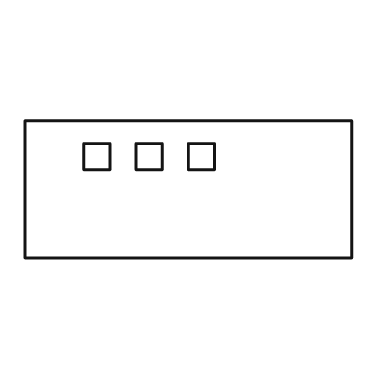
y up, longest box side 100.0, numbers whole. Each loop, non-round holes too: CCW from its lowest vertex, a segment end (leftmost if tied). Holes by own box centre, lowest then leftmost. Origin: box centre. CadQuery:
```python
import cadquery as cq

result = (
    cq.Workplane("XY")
    .moveTo(-50.0, -21.0)
    .lineTo(50.0, -21.0)
    .lineTo(50.0, 21.0)
    .lineTo(-50.0, 21.0)
    .close()
    .moveTo(-32.0, 6.0)
    .lineTo(-24.0, 6.0)
    .lineTo(-24.0, 14.0)
    .lineTo(-32.0, 14.0)
    .close()
    .moveTo(-16.0, 6.0)
    .lineTo(-8.0, 6.0)
    .lineTo(-8.0, 14.0)
    .lineTo(-16.0, 14.0)
    .close()
    .moveTo(0.0, 6.0)
    .lineTo(8.0, 6.0)
    .lineTo(8.0, 14.0)
    .lineTo(0.0, 14.0)
    .close()
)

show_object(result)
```